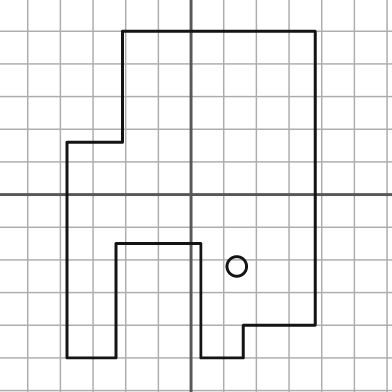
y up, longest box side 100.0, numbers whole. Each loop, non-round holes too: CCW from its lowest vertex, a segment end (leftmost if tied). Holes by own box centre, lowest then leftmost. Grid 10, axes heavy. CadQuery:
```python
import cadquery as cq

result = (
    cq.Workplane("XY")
    .moveTo(-38.0, -50.0)
    .lineTo(-23.0, -50.0)
    .lineTo(-23.0, -15.0)
    .lineTo(3.0, -15.0)
    .lineTo(3.0, -50.0)
    .lineTo(16.0, -50.0)
    .lineTo(16.0, -40.0)
    .lineTo(38.0, -40.0)
    .lineTo(38.0, 50.0)
    .lineTo(-21.0, 50.0)
    .lineTo(-21.0, 16.0)
    .lineTo(-38.0, 16.0)
    .close()
    .moveTo(14.0, -22.0)
    .circle(3.0)
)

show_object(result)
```